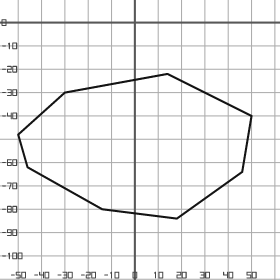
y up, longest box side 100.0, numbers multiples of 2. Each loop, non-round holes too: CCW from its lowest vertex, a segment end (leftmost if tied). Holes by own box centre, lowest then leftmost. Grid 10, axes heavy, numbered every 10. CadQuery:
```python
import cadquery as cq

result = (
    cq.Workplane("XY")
    .moveTo(18.0, -84.0)
    .lineTo(46.0, -64.0)
    .lineTo(50.0, -40.0)
    .lineTo(14.0, -22.0)
    .lineTo(-30.0, -30.0)
    .lineTo(-50.0, -48.0)
    .lineTo(-46.0, -62.0)
    .lineTo(-14.0, -80.0)
    .close()
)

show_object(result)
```